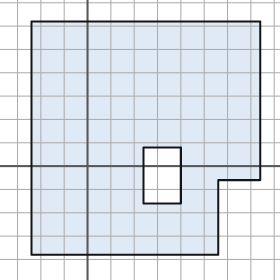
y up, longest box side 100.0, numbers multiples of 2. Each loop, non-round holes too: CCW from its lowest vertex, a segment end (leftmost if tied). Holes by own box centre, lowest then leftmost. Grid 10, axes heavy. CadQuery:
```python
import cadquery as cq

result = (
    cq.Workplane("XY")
    .moveTo(-24.0, -38.0)
    .lineTo(56.0, -38.0)
    .lineTo(56.0, -6.0)
    .lineTo(74.0, -6.0)
    .lineTo(74.0, 62.0)
    .lineTo(-24.0, 62.0)
    .close()
    .moveTo(24.0, -16.0)
    .lineTo(40.0, -16.0)
    .lineTo(40.0, 8.0)
    .lineTo(24.0, 8.0)
    .close()
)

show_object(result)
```